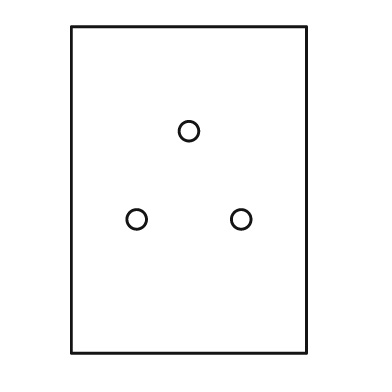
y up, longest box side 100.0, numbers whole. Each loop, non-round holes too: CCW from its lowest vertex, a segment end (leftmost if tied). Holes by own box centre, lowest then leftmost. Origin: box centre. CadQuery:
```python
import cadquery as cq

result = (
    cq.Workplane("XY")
    .moveTo(-36.0, -50.0)
    .lineTo(36.0, -50.0)
    .lineTo(36.0, 50.0)
    .lineTo(-36.0, 50.0)
    .close()
    .moveTo(-16.0, -9.0)
    .circle(3.0)
    .moveTo(16.0, -9.0)
    .circle(3.0)
    .moveTo(0.0, 18.0)
    .circle(3.0)
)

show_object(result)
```